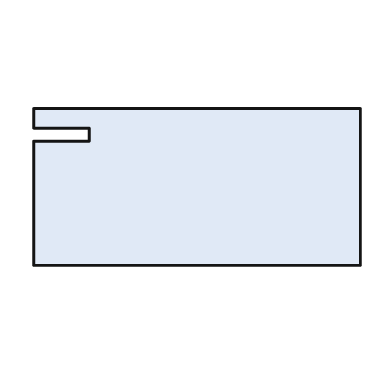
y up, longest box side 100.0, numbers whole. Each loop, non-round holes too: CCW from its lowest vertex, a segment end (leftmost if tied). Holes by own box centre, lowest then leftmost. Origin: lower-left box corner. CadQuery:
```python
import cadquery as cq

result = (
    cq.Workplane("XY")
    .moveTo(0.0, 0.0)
    .lineTo(100.0, 0.0)
    .lineTo(100.0, 48.0)
    .lineTo(0.0, 48.0)
    .lineTo(0.0, 42.0)
    .lineTo(17.0, 42.0)
    .lineTo(17.0, 38.0)
    .lineTo(0.0, 38.0)
    .close()
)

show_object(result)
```